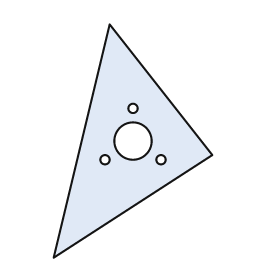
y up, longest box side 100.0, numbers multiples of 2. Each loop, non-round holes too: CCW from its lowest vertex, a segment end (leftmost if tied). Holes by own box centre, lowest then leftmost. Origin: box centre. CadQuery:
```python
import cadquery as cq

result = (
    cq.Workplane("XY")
    .moveTo(-34.0, -50.0)
    .lineTo(34.0, -6.0)
    .lineTo(-10.0, 50.0)
    .close()
    .moveTo(-12.0, -8.0)
    .circle(2.0)
    .moveTo(12.0, -8.0)
    .circle(2.0)
    .moveTo(0.0, 0.0)
    .circle(8.0)
    .moveTo(0.0, 14.0)
    .circle(2.0)
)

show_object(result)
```